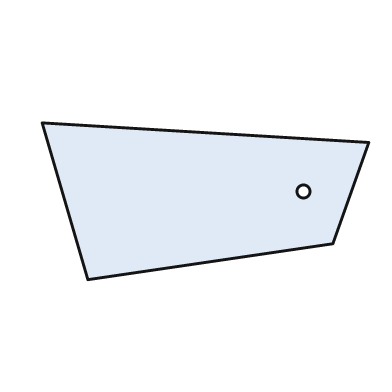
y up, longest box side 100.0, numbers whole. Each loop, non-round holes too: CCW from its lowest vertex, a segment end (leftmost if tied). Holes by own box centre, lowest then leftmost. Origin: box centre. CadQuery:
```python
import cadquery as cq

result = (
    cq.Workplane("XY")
    .moveTo(-36.0, -24.0)
    .lineTo(39.0, -13.0)
    .lineTo(50.0, 18.0)
    .lineTo(-50.0, 24.0)
    .close()
    .moveTo(30.0, 3.0)
    .circle(2.0)
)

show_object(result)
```